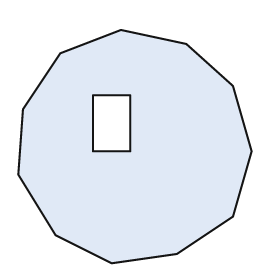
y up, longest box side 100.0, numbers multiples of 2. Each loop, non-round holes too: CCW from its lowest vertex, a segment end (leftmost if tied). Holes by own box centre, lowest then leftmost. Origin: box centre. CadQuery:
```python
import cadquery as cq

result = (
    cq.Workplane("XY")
    .moveTo(-10.0, -50.0)
    .lineTo(18.0, -46.0)
    .lineTo(42.0, -30.0)
    .lineTo(50.0, -2.0)
    .lineTo(42.0, 26.0)
    .lineTo(22.0, 44.0)
    .lineTo(-6.0, 50.0)
    .lineTo(-32.0, 40.0)
    .lineTo(-48.0, 16.0)
    .lineTo(-50.0, -12.0)
    .lineTo(-34.0, -38.0)
    .close()
    .moveTo(-18.0, -2.0)
    .lineTo(-2.0, -2.0)
    .lineTo(-2.0, 22.0)
    .lineTo(-18.0, 22.0)
    .close()
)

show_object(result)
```